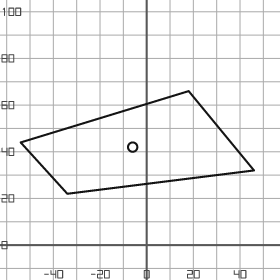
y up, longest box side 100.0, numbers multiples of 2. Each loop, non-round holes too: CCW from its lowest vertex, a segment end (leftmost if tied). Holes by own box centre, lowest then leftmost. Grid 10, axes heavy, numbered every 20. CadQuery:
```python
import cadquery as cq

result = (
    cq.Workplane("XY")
    .moveTo(-34.0, 22.0)
    .lineTo(46.0, 32.0)
    .lineTo(18.0, 66.0)
    .lineTo(-54.0, 44.0)
    .close()
    .moveTo(-6.0, 42.0)
    .circle(2.0)
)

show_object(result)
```